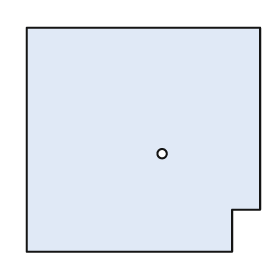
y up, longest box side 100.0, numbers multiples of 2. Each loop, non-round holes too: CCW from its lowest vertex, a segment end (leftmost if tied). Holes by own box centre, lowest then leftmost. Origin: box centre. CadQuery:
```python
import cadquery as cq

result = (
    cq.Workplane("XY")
    .moveTo(-50.0, -48.0)
    .lineTo(38.0, -48.0)
    .lineTo(38.0, -30.0)
    .lineTo(50.0, -30.0)
    .lineTo(50.0, 48.0)
    .lineTo(-50.0, 48.0)
    .close()
    .moveTo(8.0, -6.0)
    .circle(2.0)
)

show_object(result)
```